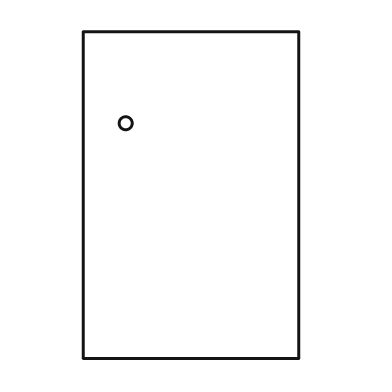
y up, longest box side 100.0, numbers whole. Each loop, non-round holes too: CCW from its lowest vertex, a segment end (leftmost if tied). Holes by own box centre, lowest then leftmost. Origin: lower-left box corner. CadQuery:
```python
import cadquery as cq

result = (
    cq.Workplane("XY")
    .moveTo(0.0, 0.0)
    .lineTo(66.0, 0.0)
    .lineTo(66.0, 100.0)
    .lineTo(0.0, 100.0)
    .close()
    .moveTo(13.0, 72.0)
    .circle(2.0)
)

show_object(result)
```